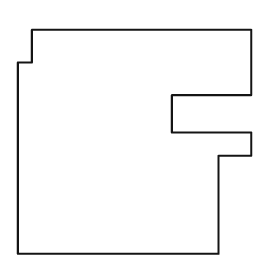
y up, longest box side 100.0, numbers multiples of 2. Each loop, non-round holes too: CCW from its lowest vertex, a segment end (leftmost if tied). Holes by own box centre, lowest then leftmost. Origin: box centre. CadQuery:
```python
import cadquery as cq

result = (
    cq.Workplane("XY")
    .moveTo(-50.0, -48.0)
    .lineTo(36.0, -48.0)
    .lineTo(36.0, -6.0)
    .lineTo(50.0, -6.0)
    .lineTo(50.0, 4.0)
    .lineTo(16.0, 4.0)
    .lineTo(16.0, 20.0)
    .lineTo(50.0, 20.0)
    .lineTo(50.0, 48.0)
    .lineTo(-44.0, 48.0)
    .lineTo(-44.0, 34.0)
    .lineTo(-50.0, 34.0)
    .close()
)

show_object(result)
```